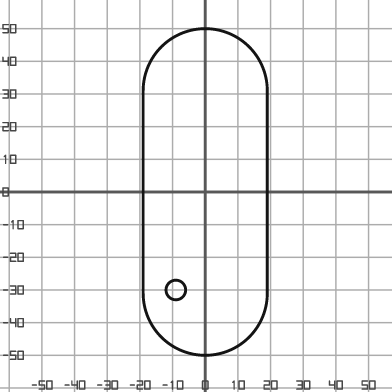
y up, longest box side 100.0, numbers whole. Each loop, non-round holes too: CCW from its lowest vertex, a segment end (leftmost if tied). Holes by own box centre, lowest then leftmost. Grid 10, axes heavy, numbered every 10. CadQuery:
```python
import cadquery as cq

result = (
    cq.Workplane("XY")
    .moveTo(-19.0, -31.0)
    .threePointArc((0.0, -50.0), (19.0, -31.0))
    .lineTo(19.0, 31.0)
    .threePointArc((0.0, 50.0), (-19.0, 31.0))
    .close()
    .moveTo(-9.0, -30.0)
    .circle(3.0)
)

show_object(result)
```